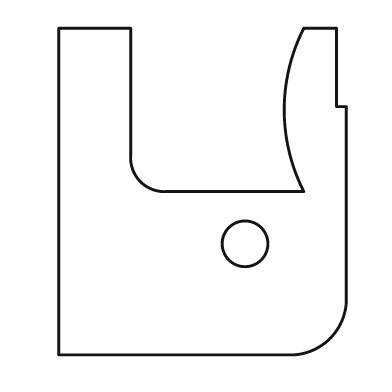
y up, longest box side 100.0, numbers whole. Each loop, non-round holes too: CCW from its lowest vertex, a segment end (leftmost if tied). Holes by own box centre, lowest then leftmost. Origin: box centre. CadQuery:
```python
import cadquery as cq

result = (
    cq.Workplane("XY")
    .moveTo(-44.0, -50.0)
    .lineTo(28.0, -50.0)
    .threePointArc((39.0, -45.0), (44.0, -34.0))
    .lineTo(44.0, 26.0)
    .lineTo(41.0, 26.0)
    .lineTo(41.0, 50.0)
    .lineTo(31.0, 50.0)
    .threePointArc((25.0, 25.0), (31.0, 0.0))
    .lineTo(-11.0, 0.0)
    .threePointArc((-19.0, 3.0), (-22.0, 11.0))
    .lineTo(-22.0, 50.0)
    .lineTo(-44.0, 50.0)
    .close()
    .moveTo(13.0, -16.0)
    .circle(7.0)
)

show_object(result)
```